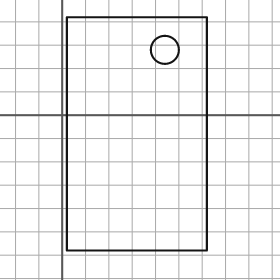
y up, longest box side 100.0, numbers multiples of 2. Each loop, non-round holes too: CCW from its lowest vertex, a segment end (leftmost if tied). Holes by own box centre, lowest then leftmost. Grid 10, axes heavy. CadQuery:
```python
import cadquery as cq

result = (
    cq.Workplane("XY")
    .moveTo(2.0, -58.0)
    .lineTo(62.0, -58.0)
    .lineTo(62.0, 42.0)
    .lineTo(2.0, 42.0)
    .close()
    .moveTo(44.0, 28.0)
    .circle(6.0)
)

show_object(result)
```